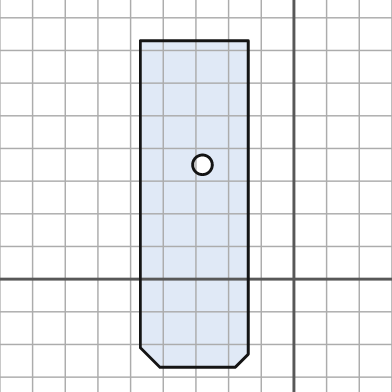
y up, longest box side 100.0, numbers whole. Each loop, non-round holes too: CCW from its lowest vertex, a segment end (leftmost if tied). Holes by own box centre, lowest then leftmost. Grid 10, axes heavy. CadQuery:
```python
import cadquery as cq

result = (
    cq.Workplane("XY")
    .moveTo(-41.0, -27.0)
    .lineTo(-18.0, -27.0)
    .lineTo(-14.0, -23.0)
    .lineTo(-14.0, 73.0)
    .lineTo(-47.0, 73.0)
    .lineTo(-47.0, -21.0)
    .close()
    .moveTo(-28.0, 35.0)
    .circle(3.0)
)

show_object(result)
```